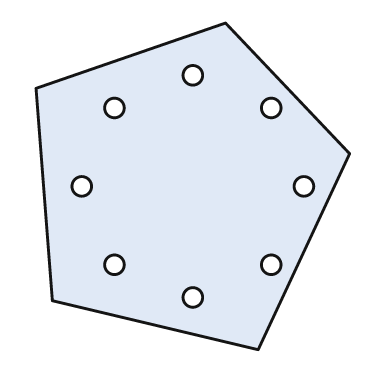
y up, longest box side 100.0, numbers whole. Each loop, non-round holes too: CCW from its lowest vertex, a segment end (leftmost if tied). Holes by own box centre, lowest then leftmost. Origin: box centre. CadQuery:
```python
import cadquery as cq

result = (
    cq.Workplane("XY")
    .moveTo(20.0, -50.0)
    .lineTo(48.0, 10.0)
    .lineTo(10.0, 50.0)
    .lineTo(-48.0, 30.0)
    .lineTo(-43.0, -35.0)
    .close()
    .moveTo(0.0, -34.0)
    .circle(3.0)
    .moveTo(-24.0, -24.0)
    .circle(3.0)
    .moveTo(24.0, -24.0)
    .circle(3.0)
    .moveTo(-34.0, 0.0)
    .circle(3.0)
    .moveTo(34.0, 0.0)
    .circle(3.0)
    .moveTo(-24.0, 24.0)
    .circle(3.0)
    .moveTo(24.0, 24.0)
    .circle(3.0)
    .moveTo(0.0, 34.0)
    .circle(3.0)
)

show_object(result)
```